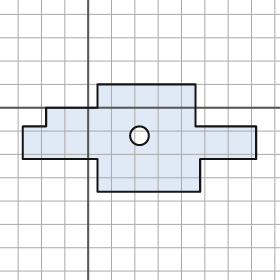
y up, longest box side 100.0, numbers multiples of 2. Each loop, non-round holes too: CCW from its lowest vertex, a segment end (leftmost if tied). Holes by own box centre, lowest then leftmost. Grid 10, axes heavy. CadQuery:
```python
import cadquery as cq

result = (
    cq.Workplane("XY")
    .moveTo(4.0, -36.0)
    .lineTo(48.0, -36.0)
    .lineTo(48.0, -22.0)
    .lineTo(72.0, -22.0)
    .lineTo(72.0, -8.0)
    .lineTo(46.0, -8.0)
    .lineTo(46.0, 10.0)
    .lineTo(4.0, 10.0)
    .lineTo(4.0, 0.0)
    .lineTo(-18.0, 0.0)
    .lineTo(-18.0, -8.0)
    .lineTo(-28.0, -8.0)
    .lineTo(-28.0, -22.0)
    .lineTo(4.0, -22.0)
    .close()
    .moveTo(22.0, -12.0)
    .circle(4.0)
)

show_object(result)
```